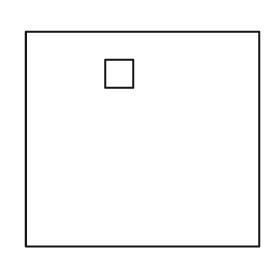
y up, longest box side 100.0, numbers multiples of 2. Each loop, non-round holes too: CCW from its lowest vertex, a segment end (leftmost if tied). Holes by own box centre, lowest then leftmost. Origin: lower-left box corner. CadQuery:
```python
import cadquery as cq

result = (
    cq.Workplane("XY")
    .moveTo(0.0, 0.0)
    .lineTo(100.0, 0.0)
    .lineTo(100.0, 92.0)
    .lineTo(0.0, 92.0)
    .close()
    .moveTo(34.0, 68.0)
    .lineTo(46.0, 68.0)
    .lineTo(46.0, 80.0)
    .lineTo(34.0, 80.0)
    .close()
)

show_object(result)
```